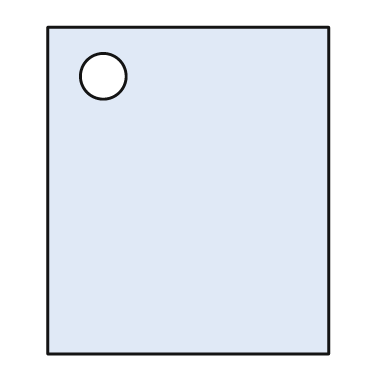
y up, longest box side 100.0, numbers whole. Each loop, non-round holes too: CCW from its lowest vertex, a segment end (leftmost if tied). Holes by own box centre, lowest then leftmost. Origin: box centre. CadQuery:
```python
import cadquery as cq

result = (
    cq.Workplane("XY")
    .moveTo(-43.0, -50.0)
    .lineTo(43.0, -50.0)
    .lineTo(43.0, 50.0)
    .lineTo(-43.0, 50.0)
    .close()
    .moveTo(-26.0, 35.0)
    .circle(7.0)
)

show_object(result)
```